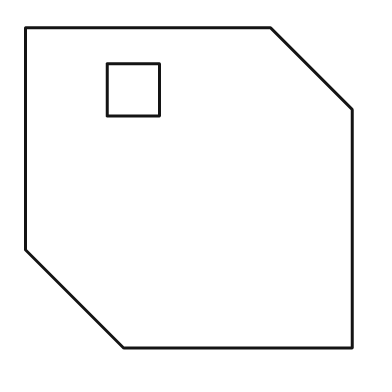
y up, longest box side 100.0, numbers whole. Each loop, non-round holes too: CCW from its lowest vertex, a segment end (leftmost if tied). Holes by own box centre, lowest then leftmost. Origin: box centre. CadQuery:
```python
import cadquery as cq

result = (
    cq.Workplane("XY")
    .moveTo(-20.0, -49.0)
    .lineTo(50.0, -49.0)
    .lineTo(50.0, 24.0)
    .lineTo(25.0, 49.0)
    .lineTo(-50.0, 49.0)
    .lineTo(-50.0, -19.0)
    .close()
    .moveTo(-25.0, 22.0)
    .lineTo(-9.0, 22.0)
    .lineTo(-9.0, 38.0)
    .lineTo(-25.0, 38.0)
    .close()
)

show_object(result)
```